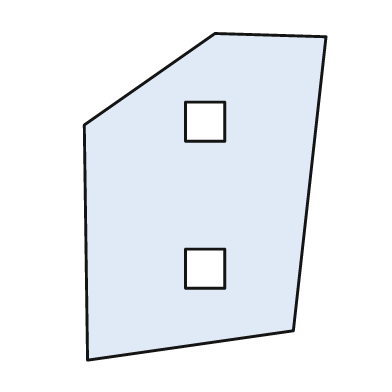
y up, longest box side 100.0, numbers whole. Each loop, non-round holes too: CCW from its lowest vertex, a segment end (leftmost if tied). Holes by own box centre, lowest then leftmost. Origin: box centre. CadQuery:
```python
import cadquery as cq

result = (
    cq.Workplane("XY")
    .moveTo(-36.0, -50.0)
    .lineTo(27.0, -41.0)
    .lineTo(37.0, 49.0)
    .lineTo(3.0, 50.0)
    .lineTo(-37.0, 22.0)
    .close()
    .moveTo(-6.0, -28.0)
    .lineTo(6.0, -28.0)
    .lineTo(6.0, -16.0)
    .lineTo(-6.0, -16.0)
    .close()
    .moveTo(-6.0, 17.0)
    .lineTo(6.0, 17.0)
    .lineTo(6.0, 29.0)
    .lineTo(-6.0, 29.0)
    .close()
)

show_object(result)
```